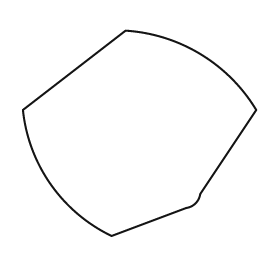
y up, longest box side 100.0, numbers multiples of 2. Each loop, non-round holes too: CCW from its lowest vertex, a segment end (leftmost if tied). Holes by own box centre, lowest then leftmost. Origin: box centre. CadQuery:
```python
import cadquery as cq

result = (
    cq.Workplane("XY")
    .moveTo(-12.0, -44.0)
    .lineTo(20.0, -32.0)
    .threePointArc((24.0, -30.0), (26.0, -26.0))
    .lineTo(50.0, 10.0)
    .threePointArc((26.0, 34.0), (-6.0, 44.0))
    .lineTo(-50.0, 10.0)
    .threePointArc((-38.0, -22.0), (-12.0, -44.0))
    .close()
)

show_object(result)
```